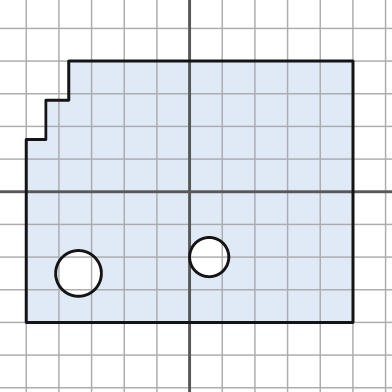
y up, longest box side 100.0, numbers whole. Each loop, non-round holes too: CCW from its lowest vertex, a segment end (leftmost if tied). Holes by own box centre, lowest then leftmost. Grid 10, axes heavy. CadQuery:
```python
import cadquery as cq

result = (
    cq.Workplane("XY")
    .moveTo(-50.0, -40.0)
    .lineTo(50.0, -40.0)
    .lineTo(50.0, 40.0)
    .lineTo(-37.0, 40.0)
    .lineTo(-37.0, 28.0)
    .lineTo(-44.0, 28.0)
    .lineTo(-44.0, 16.0)
    .lineTo(-50.0, 16.0)
    .close()
    .moveTo(-34.0, -25.0)
    .circle(7.0)
    .moveTo(6.0, -20.0)
    .circle(6.0)
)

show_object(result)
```